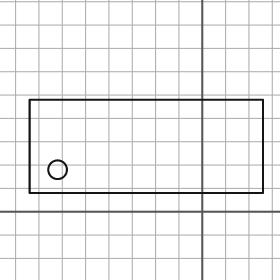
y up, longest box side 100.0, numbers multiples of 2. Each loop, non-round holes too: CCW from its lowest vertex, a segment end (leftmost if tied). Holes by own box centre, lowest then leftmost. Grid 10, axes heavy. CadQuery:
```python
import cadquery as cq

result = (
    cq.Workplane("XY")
    .moveTo(-74.0, 8.0)
    .lineTo(26.0, 8.0)
    .lineTo(26.0, 48.0)
    .lineTo(-74.0, 48.0)
    .close()
    .moveTo(-62.0, 18.0)
    .circle(4.0)
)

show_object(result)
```